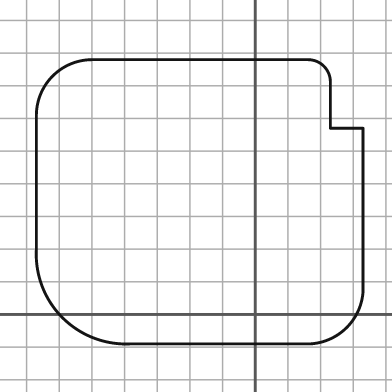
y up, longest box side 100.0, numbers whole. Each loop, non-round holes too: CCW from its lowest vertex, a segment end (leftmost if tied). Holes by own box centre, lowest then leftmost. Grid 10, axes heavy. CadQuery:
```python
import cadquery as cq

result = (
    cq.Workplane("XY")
    .moveTo(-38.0, -9.0)
    .lineTo(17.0, -9.0)
    .threePointArc((28.0, -4.0), (33.0, 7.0))
    .lineTo(33.0, 57.0)
    .lineTo(23.0, 57.0)
    .lineTo(23.0, 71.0)
    .threePointArc((21.0, 76.0), (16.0, 78.0))
    .lineTo(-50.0, 78.0)
    .threePointArc((-62.0, 73.0), (-67.0, 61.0))
    .lineTo(-67.0, 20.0)
    .threePointArc((-59.0, -1.0), (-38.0, -9.0))
    .close()
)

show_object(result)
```